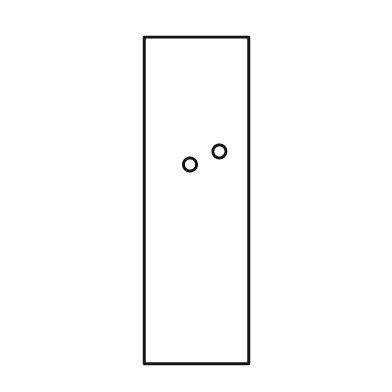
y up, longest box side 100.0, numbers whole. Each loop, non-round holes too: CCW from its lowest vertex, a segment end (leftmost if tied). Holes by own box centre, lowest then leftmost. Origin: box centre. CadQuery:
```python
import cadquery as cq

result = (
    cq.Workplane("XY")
    .moveTo(-16.0, -50.0)
    .lineTo(16.0, -50.0)
    .lineTo(16.0, 50.0)
    .lineTo(-16.0, 50.0)
    .close()
    .moveTo(-2.0, 11.0)
    .circle(2.0)
    .moveTo(7.0, 15.0)
    .circle(2.0)
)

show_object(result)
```